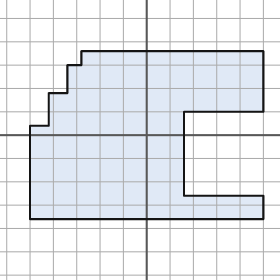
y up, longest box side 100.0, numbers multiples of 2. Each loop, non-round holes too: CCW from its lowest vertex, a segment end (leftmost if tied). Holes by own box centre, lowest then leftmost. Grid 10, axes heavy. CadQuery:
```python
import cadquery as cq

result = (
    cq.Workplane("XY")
    .moveTo(-50.0, -36.0)
    .lineTo(50.0, -36.0)
    .lineTo(50.0, -26.0)
    .lineTo(16.0, -26.0)
    .lineTo(16.0, 10.0)
    .lineTo(50.0, 10.0)
    .lineTo(50.0, 36.0)
    .lineTo(-28.0, 36.0)
    .lineTo(-28.0, 30.0)
    .lineTo(-34.0, 30.0)
    .lineTo(-34.0, 18.0)
    .lineTo(-42.0, 18.0)
    .lineTo(-42.0, 4.0)
    .lineTo(-50.0, 4.0)
    .close()
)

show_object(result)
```